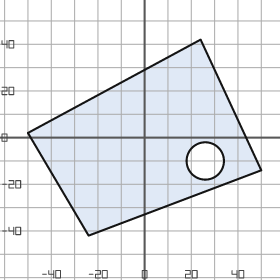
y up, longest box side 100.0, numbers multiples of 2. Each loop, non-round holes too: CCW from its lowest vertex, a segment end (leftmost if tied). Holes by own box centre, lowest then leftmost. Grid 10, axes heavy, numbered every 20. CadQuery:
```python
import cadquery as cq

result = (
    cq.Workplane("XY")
    .moveTo(-24.0, -42.0)
    .lineTo(50.0, -14.0)
    .lineTo(24.0, 42.0)
    .lineTo(-50.0, 2.0)
    .close()
    .moveTo(26.0, -10.0)
    .circle(8.0)
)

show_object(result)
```